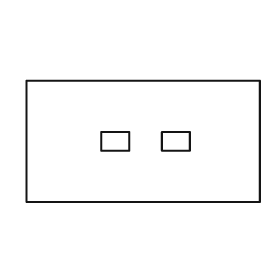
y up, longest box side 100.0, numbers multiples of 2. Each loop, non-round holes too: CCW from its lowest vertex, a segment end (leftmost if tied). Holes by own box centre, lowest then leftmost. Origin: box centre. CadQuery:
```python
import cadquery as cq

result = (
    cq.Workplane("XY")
    .moveTo(-50.0, -26.0)
    .lineTo(50.0, -26.0)
    .lineTo(50.0, 26.0)
    .lineTo(-50.0, 26.0)
    .close()
    .moveTo(-18.0, -4.0)
    .lineTo(-6.0, -4.0)
    .lineTo(-6.0, 4.0)
    .lineTo(-18.0, 4.0)
    .close()
    .moveTo(8.0, -4.0)
    .lineTo(20.0, -4.0)
    .lineTo(20.0, 4.0)
    .lineTo(8.0, 4.0)
    .close()
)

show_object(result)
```